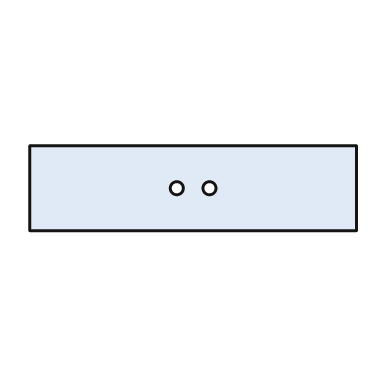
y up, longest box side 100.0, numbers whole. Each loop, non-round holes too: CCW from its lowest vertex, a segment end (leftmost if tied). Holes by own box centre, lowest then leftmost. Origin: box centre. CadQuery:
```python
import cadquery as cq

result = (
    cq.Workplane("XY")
    .moveTo(-50.0, -13.0)
    .lineTo(50.0, -13.0)
    .lineTo(50.0, 13.0)
    .lineTo(-50.0, 13.0)
    .close()
    .moveTo(-5.0, 0.0)
    .circle(2.0)
    .moveTo(5.0, 0.0)
    .circle(2.0)
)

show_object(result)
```